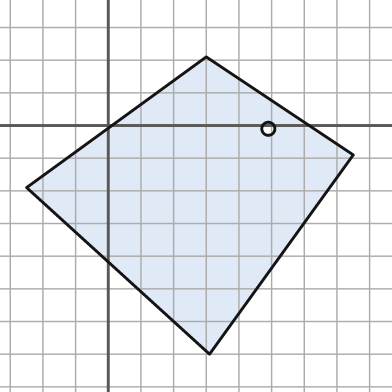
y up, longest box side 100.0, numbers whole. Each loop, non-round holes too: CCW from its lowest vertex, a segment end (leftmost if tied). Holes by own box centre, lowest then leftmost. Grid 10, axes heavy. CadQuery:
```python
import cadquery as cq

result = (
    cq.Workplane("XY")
    .moveTo(31.0, -70.0)
    .lineTo(75.0, -9.0)
    .lineTo(30.0, 21.0)
    .lineTo(-25.0, -19.0)
    .close()
    .moveTo(49.0, -1.0)
    .circle(2.0)
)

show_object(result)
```